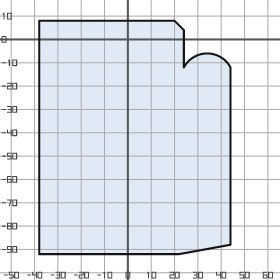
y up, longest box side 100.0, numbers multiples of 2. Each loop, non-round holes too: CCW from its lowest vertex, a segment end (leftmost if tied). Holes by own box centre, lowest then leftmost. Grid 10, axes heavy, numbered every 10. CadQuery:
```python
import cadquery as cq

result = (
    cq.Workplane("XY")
    .moveTo(-38.0, -92.0)
    .lineTo(22.0, -92.0)
    .lineTo(44.0, -88.0)
    .lineTo(44.0, -12.0)
    .threePointArc((34.0, -6.0), (24.0, -12.0))
    .lineTo(24.0, 4.0)
    .lineTo(20.0, 8.0)
    .lineTo(-38.0, 8.0)
    .close()
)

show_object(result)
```